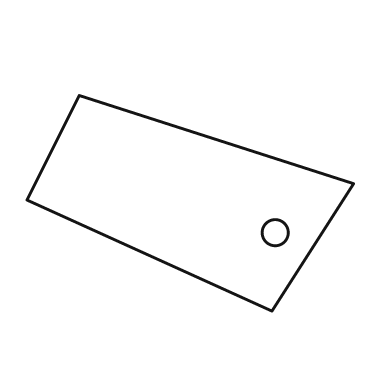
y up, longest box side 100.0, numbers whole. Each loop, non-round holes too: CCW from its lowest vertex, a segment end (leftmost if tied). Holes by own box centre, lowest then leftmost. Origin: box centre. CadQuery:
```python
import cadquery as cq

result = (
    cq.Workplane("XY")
    .moveTo(25.0, -33.0)
    .lineTo(50.0, 6.0)
    .lineTo(-34.0, 33.0)
    .lineTo(-50.0, 1.0)
    .close()
    .moveTo(26.0, -9.0)
    .circle(4.0)
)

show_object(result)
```